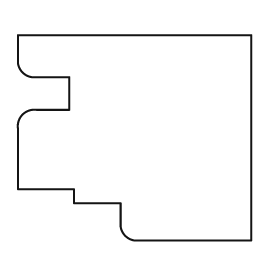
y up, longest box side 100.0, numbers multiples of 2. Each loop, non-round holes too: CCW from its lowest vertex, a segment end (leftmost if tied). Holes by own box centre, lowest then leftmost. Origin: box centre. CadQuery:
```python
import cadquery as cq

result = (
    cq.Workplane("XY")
    .moveTo(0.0, -44.0)
    .lineTo(50.0, -44.0)
    .lineTo(50.0, 44.0)
    .lineTo(-50.0, 44.0)
    .lineTo(-50.0, 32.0)
    .threePointArc((-48.0, 28.0), (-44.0, 26.0))
    .lineTo(-28.0, 26.0)
    .lineTo(-28.0, 12.0)
    .lineTo(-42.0, 12.0)
    .threePointArc((-48.0, 10.0), (-50.0, 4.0))
    .lineTo(-50.0, -22.0)
    .lineTo(-26.0, -22.0)
    .lineTo(-26.0, -28.0)
    .lineTo(-6.0, -28.0)
    .lineTo(-6.0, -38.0)
    .threePointArc((-4.0, -42.0), (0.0, -44.0))
    .close()
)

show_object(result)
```